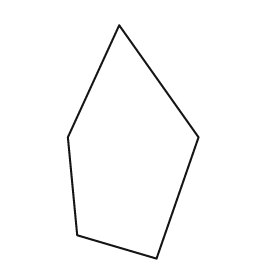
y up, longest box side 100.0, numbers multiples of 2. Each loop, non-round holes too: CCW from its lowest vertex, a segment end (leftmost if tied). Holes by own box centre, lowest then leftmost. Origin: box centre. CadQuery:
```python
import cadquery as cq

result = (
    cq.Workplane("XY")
    .moveTo(10.0, -50.0)
    .lineTo(28.0, 2.0)
    .lineTo(-6.0, 50.0)
    .lineTo(-28.0, 2.0)
    .lineTo(-24.0, -40.0)
    .close()
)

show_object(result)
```